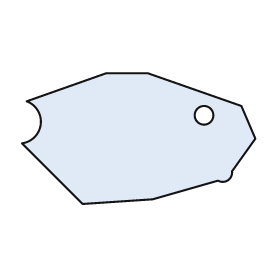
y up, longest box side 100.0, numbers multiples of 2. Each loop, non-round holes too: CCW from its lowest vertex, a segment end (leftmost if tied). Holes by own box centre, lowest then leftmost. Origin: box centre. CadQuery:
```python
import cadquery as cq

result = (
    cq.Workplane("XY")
    .moveTo(-24.0, -28.0)
    .lineTo(6.0, -26.0)
    .lineTo(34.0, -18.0)
    .threePointArc((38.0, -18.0), (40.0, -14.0))
    .lineTo(50.0, 0.0)
    .lineTo(44.0, 14.0)
    .lineTo(4.0, 28.0)
    .lineTo(-14.0, 28.0)
    .lineTo(-48.0, 16.0)
    .threePointArc((-42.0, 6.0), (-50.0, -2.0))
    .close()
    .moveTo(28.0, 10.0)
    .circle(4.0)
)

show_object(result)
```